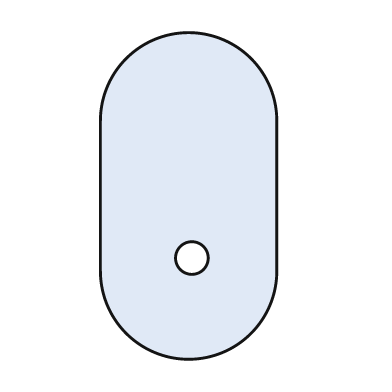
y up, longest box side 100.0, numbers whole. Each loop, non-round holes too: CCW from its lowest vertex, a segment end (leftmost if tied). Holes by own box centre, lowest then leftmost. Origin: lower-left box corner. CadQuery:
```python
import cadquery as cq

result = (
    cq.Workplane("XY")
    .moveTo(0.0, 27.0)
    .threePointArc((27.0, 0.0), (54.0, 27.0))
    .lineTo(54.0, 73.0)
    .threePointArc((27.0, 100.0), (0.0, 73.0))
    .close()
    .moveTo(28.0, 31.0)
    .circle(5.0)
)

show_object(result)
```